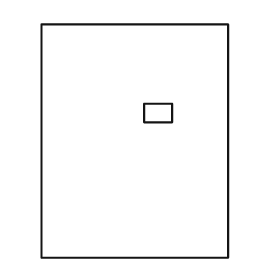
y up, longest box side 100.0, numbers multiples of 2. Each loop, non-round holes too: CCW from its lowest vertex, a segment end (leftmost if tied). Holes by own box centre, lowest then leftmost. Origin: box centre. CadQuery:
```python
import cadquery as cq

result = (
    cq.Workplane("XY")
    .moveTo(-40.0, -50.0)
    .lineTo(40.0, -50.0)
    .lineTo(40.0, 50.0)
    .lineTo(-40.0, 50.0)
    .close()
    .moveTo(4.0, 8.0)
    .lineTo(16.0, 8.0)
    .lineTo(16.0, 16.0)
    .lineTo(4.0, 16.0)
    .close()
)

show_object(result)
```